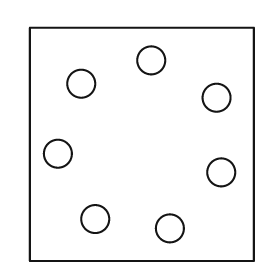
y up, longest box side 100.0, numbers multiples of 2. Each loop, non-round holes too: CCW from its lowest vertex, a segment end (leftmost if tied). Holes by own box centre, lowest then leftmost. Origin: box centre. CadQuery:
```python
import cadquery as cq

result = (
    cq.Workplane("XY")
    .moveTo(-48.0, -50.0)
    .lineTo(48.0, -50.0)
    .lineTo(48.0, 50.0)
    .lineTo(-48.0, 50.0)
    .close()
    .moveTo(12.0, -36.0)
    .circle(6.0)
    .moveTo(-20.0, -32.0)
    .circle(6.0)
    .moveTo(34.0, -12.0)
    .circle(6.0)
    .moveTo(-36.0, -4.0)
    .circle(6.0)
    .moveTo(32.0, 20.0)
    .circle(6.0)
    .moveTo(-26.0, 26.0)
    .circle(6.0)
    .moveTo(4.0, 36.0)
    .circle(6.0)
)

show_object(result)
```